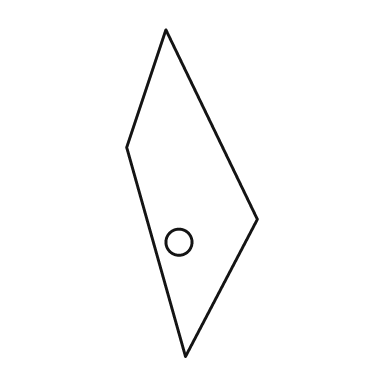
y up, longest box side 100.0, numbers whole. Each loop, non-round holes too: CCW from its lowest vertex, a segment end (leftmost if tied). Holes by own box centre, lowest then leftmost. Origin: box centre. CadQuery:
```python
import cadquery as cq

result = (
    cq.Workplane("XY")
    .moveTo(-2.0, -50.0)
    .lineTo(20.0, -8.0)
    .lineTo(-8.0, 50.0)
    .lineTo(-20.0, 14.0)
    .close()
    .moveTo(-4.0, -15.0)
    .circle(4.0)
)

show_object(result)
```